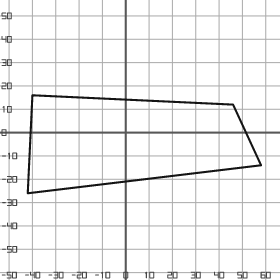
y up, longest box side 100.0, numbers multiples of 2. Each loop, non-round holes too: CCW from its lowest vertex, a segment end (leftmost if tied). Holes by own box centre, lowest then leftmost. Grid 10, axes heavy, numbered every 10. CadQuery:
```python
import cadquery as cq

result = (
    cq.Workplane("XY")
    .moveTo(-42.0, -26.0)
    .lineTo(58.0, -14.0)
    .lineTo(46.0, 12.0)
    .lineTo(-40.0, 16.0)
    .close()
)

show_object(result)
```